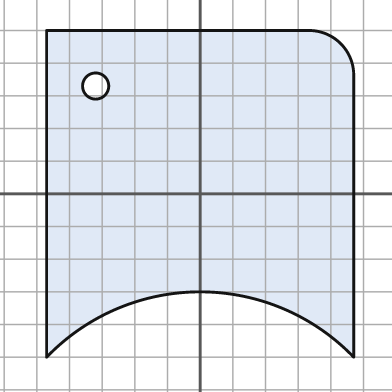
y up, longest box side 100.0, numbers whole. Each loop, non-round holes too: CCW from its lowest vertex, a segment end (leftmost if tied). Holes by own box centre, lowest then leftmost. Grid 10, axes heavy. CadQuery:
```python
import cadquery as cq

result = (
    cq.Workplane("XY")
    .moveTo(-47.0, -50.0)
    .threePointArc((0.0, -30.0), (47.0, -50.0))
    .lineTo(47.0, 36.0)
    .threePointArc((43.0, 46.0), (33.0, 50.0))
    .lineTo(-47.0, 50.0)
    .close()
    .moveTo(-32.0, 33.0)
    .circle(4.0)
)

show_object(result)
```